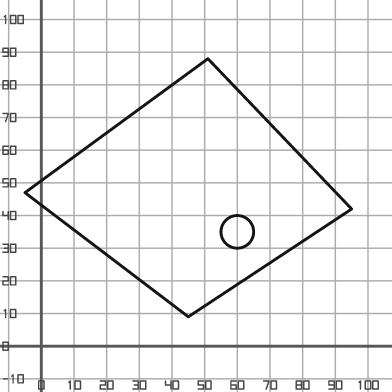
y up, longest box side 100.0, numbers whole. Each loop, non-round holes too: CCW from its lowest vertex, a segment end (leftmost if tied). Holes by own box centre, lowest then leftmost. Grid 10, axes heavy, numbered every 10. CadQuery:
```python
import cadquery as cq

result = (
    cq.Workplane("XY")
    .moveTo(45.0, 9.0)
    .lineTo(95.0, 42.0)
    .lineTo(51.0, 88.0)
    .lineTo(-5.0, 47.0)
    .close()
    .moveTo(60.0, 35.0)
    .circle(5.0)
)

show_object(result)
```